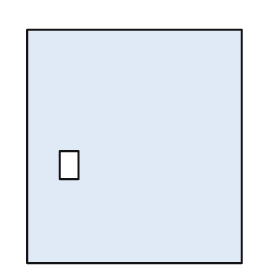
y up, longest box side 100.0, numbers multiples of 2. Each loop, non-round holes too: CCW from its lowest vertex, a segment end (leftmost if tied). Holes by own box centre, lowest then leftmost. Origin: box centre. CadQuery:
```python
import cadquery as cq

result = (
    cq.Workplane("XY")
    .moveTo(-46.0, -50.0)
    .lineTo(46.0, -50.0)
    .lineTo(46.0, 50.0)
    .lineTo(-46.0, 50.0)
    .close()
    .moveTo(-32.0, -14.0)
    .lineTo(-24.0, -14.0)
    .lineTo(-24.0, -2.0)
    .lineTo(-32.0, -2.0)
    .close()
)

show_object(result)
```